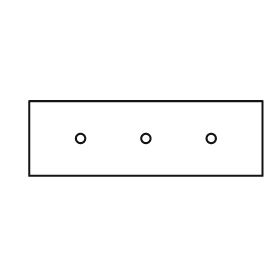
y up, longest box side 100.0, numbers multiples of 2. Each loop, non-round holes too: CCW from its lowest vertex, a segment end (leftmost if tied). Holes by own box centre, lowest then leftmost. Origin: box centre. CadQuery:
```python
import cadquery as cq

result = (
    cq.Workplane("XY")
    .moveTo(-50.0, -16.0)
    .lineTo(50.0, -16.0)
    .lineTo(50.0, 16.0)
    .lineTo(-50.0, 16.0)
    .close()
    .moveTo(-28.0, 0.0)
    .circle(2.0)
    .moveTo(0.0, 0.0)
    .circle(2.0)
    .moveTo(28.0, 0.0)
    .circle(2.0)
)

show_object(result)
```